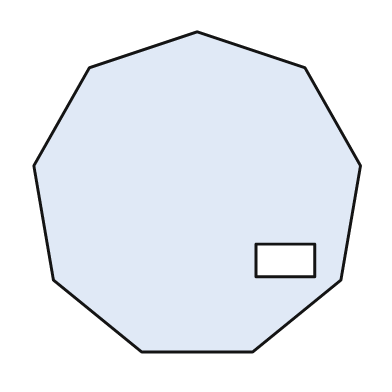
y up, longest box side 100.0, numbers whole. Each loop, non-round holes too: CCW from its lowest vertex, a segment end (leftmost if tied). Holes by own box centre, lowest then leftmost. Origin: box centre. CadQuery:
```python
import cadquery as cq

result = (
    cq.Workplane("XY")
    .moveTo(-17.0, -49.0)
    .lineTo(17.0, -49.0)
    .lineTo(44.0, -27.0)
    .lineTo(50.0, 8.0)
    .lineTo(33.0, 38.0)
    .lineTo(0.0, 49.0)
    .lineTo(-33.0, 38.0)
    .lineTo(-50.0, 8.0)
    .lineTo(-44.0, -27.0)
    .close()
    .moveTo(18.0, -26.0)
    .lineTo(36.0, -26.0)
    .lineTo(36.0, -16.0)
    .lineTo(18.0, -16.0)
    .close()
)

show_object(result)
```